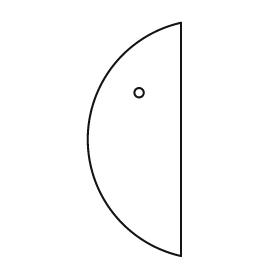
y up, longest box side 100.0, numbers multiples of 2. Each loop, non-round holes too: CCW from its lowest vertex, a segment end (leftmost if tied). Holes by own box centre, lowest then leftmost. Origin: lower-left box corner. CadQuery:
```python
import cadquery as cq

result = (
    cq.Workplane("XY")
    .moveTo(40.0, 0.0)
    .lineTo(40.0, 100.0)
    .threePointArc((0.0, 50.0), (40.0, 0.0))
    .close()
    .moveTo(22.0, 70.0)
    .circle(2.0)
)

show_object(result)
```